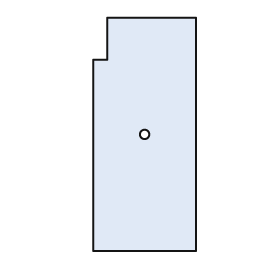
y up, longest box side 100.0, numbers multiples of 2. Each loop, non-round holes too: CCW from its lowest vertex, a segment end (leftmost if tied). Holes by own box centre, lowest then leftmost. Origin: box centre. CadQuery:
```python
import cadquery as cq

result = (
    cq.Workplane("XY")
    .moveTo(-22.0, -50.0)
    .lineTo(22.0, -50.0)
    .lineTo(22.0, 50.0)
    .lineTo(-16.0, 50.0)
    .lineTo(-16.0, 32.0)
    .lineTo(-22.0, 32.0)
    .close()
    .moveTo(0.0, 0.0)
    .circle(2.0)
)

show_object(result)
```